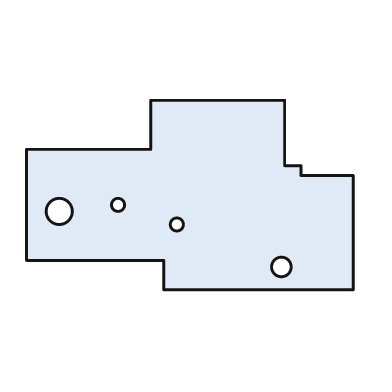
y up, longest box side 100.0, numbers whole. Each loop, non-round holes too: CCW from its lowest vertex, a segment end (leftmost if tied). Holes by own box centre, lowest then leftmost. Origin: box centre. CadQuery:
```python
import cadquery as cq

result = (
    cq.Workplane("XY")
    .moveTo(-8.0, -29.0)
    .lineTo(50.0, -29.0)
    .lineTo(50.0, 6.0)
    .lineTo(34.0, 6.0)
    .lineTo(34.0, 9.0)
    .lineTo(29.0, 9.0)
    .lineTo(29.0, 29.0)
    .lineTo(-12.0, 29.0)
    .lineTo(-12.0, 14.0)
    .lineTo(-50.0, 14.0)
    .lineTo(-50.0, -20.0)
    .lineTo(-8.0, -20.0)
    .close()
    .moveTo(28.0, -22.0)
    .circle(3.0)
    .moveTo(-4.0, -9.0)
    .circle(2.0)
    .moveTo(-40.0, -5.0)
    .circle(4.0)
    .moveTo(-22.0, -3.0)
    .circle(2.0)
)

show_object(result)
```